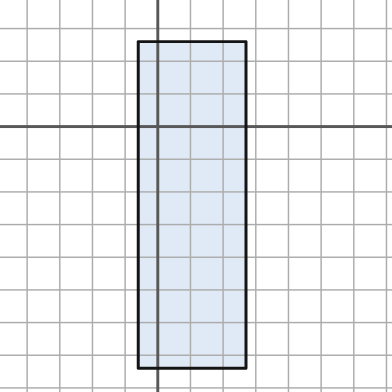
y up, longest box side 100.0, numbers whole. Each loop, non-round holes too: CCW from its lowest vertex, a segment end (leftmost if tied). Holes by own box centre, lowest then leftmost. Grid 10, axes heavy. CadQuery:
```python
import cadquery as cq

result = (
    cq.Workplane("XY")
    .moveTo(-6.0, -74.0)
    .lineTo(27.0, -74.0)
    .lineTo(27.0, 26.0)
    .lineTo(-6.0, 26.0)
    .close()
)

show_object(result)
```